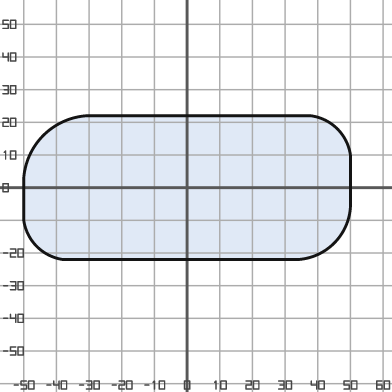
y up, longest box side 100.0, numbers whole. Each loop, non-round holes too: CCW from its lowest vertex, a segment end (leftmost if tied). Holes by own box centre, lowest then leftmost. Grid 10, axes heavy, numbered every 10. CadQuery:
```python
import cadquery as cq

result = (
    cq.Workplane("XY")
    .moveTo(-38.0, -22.0)
    .lineTo(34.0, -22.0)
    .threePointArc((45.0, -17.0), (50.0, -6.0))
    .lineTo(50.0, 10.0)
    .threePointArc((46.0, 18.0), (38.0, 22.0))
    .lineTo(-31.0, 22.0)
    .threePointArc((-44.0, 16.0), (-50.0, 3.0))
    .lineTo(-50.0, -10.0)
    .threePointArc((-46.0, -18.0), (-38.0, -22.0))
    .close()
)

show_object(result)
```